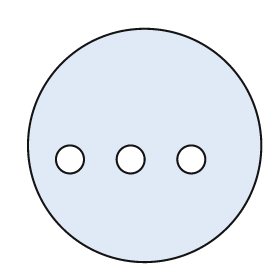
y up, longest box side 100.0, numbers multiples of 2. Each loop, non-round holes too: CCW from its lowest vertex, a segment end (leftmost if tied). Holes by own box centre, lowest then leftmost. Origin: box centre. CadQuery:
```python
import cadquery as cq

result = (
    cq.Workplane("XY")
    .moveTo(0.0, 0.0)
    .circle(50.0)
    .moveTo(-32.0, -6.0)
    .circle(6.0)
    .moveTo(-6.0, -6.0)
    .circle(6.0)
    .moveTo(20.0, -6.0)
    .circle(6.0)
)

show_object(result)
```